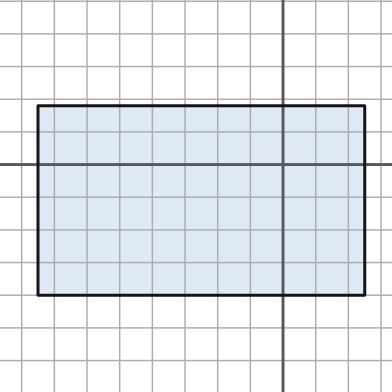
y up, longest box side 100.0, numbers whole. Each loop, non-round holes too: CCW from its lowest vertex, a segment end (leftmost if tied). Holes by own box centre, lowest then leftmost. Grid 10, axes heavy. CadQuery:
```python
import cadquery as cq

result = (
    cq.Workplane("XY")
    .moveTo(-75.0, -40.0)
    .lineTo(25.0, -40.0)
    .lineTo(25.0, 18.0)
    .lineTo(-75.0, 18.0)
    .close()
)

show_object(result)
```